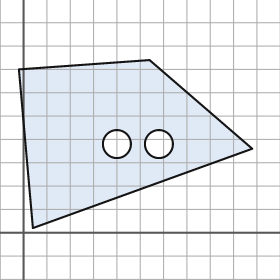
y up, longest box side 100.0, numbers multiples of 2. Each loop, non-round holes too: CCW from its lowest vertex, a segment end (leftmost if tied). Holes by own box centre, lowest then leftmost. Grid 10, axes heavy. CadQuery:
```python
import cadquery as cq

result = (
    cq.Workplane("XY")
    .moveTo(4.0, 2.0)
    .lineTo(98.0, 36.0)
    .lineTo(54.0, 74.0)
    .lineTo(-2.0, 70.0)
    .close()
    .moveTo(40.0, 38.0)
    .circle(6.0)
    .moveTo(58.0, 38.0)
    .circle(6.0)
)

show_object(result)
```